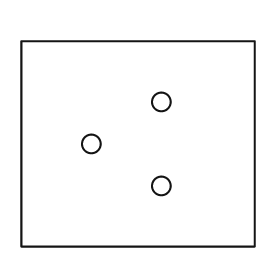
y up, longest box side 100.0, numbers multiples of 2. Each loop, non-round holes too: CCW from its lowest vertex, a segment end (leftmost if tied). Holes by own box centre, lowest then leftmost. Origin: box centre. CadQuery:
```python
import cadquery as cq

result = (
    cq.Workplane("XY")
    .moveTo(-50.0, -44.0)
    .lineTo(50.0, -44.0)
    .lineTo(50.0, 44.0)
    .lineTo(-50.0, 44.0)
    .close()
    .moveTo(10.0, -18.0)
    .circle(4.0)
    .moveTo(-20.0, 0.0)
    .circle(4.0)
    .moveTo(10.0, 18.0)
    .circle(4.0)
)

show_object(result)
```